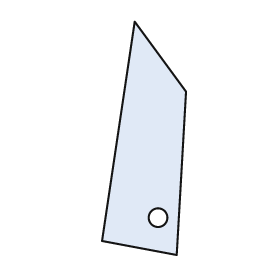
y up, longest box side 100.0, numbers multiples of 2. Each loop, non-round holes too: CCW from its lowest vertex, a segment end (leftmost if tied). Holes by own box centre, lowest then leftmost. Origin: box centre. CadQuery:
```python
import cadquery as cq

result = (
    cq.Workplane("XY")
    .moveTo(14.0, -50.0)
    .lineTo(18.0, 20.0)
    .lineTo(-4.0, 50.0)
    .lineTo(-18.0, -44.0)
    .close()
    .moveTo(6.0, -34.0)
    .circle(4.0)
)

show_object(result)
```